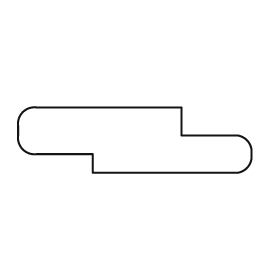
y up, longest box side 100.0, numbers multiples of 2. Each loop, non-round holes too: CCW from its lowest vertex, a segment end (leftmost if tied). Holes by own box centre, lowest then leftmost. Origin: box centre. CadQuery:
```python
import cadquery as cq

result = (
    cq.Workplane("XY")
    .moveTo(-18.0, -14.0)
    .lineTo(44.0, -14.0)
    .threePointArc((48.0, -12.0), (50.0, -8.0))
    .lineTo(50.0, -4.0)
    .threePointArc((48.0, 0.0), (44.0, 2.0))
    .lineTo(20.0, 2.0)
    .lineTo(20.0, 14.0)
    .lineTo(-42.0, 14.0)
    .threePointArc((-48.0, 12.0), (-50.0, 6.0))
    .lineTo(-50.0, 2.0)
    .threePointArc((-48.0, -4.0), (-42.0, -6.0))
    .lineTo(-18.0, -6.0)
    .close()
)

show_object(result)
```